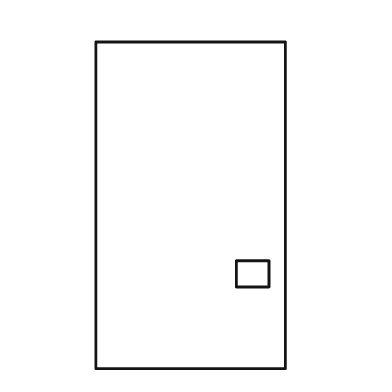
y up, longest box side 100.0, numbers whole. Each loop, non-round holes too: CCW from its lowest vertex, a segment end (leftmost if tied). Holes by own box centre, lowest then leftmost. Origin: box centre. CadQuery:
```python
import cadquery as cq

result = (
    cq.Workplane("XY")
    .moveTo(-29.0, -50.0)
    .lineTo(29.0, -50.0)
    .lineTo(29.0, 50.0)
    .lineTo(-29.0, 50.0)
    .close()
    .moveTo(14.0, -25.0)
    .lineTo(24.0, -25.0)
    .lineTo(24.0, -17.0)
    .lineTo(14.0, -17.0)
    .close()
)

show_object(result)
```